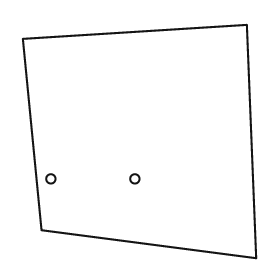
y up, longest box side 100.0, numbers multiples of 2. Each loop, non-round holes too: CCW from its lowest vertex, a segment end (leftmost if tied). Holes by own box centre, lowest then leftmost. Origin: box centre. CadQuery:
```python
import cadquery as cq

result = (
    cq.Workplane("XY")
    .moveTo(50.0, -50.0)
    .lineTo(46.0, 50.0)
    .lineTo(-50.0, 44.0)
    .lineTo(-42.0, -38.0)
    .close()
    .moveTo(-38.0, -16.0)
    .circle(2.0)
    .moveTo(-2.0, -16.0)
    .circle(2.0)
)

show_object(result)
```